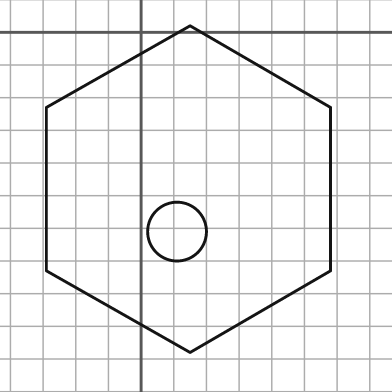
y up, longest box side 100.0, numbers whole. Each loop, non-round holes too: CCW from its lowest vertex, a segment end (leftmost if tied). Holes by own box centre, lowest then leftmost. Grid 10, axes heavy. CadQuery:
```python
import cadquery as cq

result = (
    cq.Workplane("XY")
    .moveTo(15.0, -98.0)
    .lineTo(58.0, -73.0)
    .lineTo(58.0, -23.0)
    .lineTo(15.0, 2.0)
    .lineTo(-29.0, -23.0)
    .lineTo(-29.0, -73.0)
    .close()
    .moveTo(11.0, -61.0)
    .circle(9.0)
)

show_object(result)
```